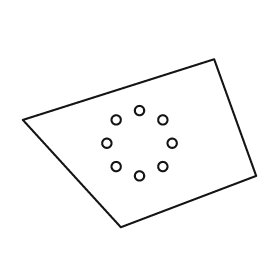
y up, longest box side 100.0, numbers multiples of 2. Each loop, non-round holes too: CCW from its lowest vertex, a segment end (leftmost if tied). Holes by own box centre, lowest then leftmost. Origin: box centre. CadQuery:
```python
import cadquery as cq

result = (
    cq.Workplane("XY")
    .moveTo(-8.0, -36.0)
    .lineTo(50.0, -14.0)
    .lineTo(32.0, 36.0)
    .lineTo(-50.0, 10.0)
    .close()
    .moveTo(0.0, -14.0)
    .circle(2.0)
    .moveTo(-10.0, -10.0)
    .circle(2.0)
    .moveTo(10.0, -10.0)
    .circle(2.0)
    .moveTo(-14.0, 0.0)
    .circle(2.0)
    .moveTo(14.0, 0.0)
    .circle(2.0)
    .moveTo(-10.0, 10.0)
    .circle(2.0)
    .moveTo(10.0, 10.0)
    .circle(2.0)
    .moveTo(0.0, 14.0)
    .circle(2.0)
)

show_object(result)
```